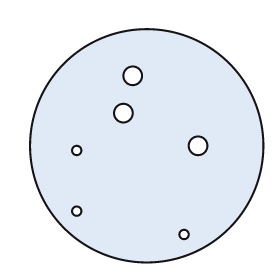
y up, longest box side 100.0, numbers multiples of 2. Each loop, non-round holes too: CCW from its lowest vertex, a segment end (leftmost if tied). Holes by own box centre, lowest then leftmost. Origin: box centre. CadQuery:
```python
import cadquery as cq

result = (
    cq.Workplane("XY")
    .moveTo(0.0, 0.0)
    .circle(50.0)
    .moveTo(16.0, -38.0)
    .circle(2.0)
    .moveTo(-30.0, -28.0)
    .circle(2.0)
    .moveTo(-30.0, -2.0)
    .circle(2.0)
    .moveTo(22.0, 0.0)
    .circle(4.0)
    .moveTo(-10.0, 14.0)
    .circle(4.0)
    .moveTo(-6.0, 30.0)
    .circle(4.0)
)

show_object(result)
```